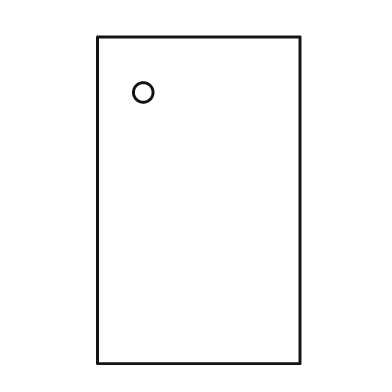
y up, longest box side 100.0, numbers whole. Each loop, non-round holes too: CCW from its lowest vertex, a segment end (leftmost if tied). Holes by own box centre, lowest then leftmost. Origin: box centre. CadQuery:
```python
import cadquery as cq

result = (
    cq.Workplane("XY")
    .moveTo(-31.0, -50.0)
    .lineTo(31.0, -50.0)
    .lineTo(31.0, 50.0)
    .lineTo(-31.0, 50.0)
    .close()
    .moveTo(-17.0, 33.0)
    .circle(3.0)
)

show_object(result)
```